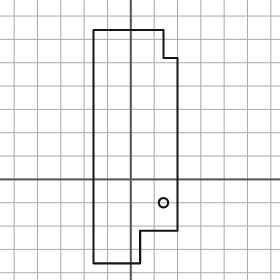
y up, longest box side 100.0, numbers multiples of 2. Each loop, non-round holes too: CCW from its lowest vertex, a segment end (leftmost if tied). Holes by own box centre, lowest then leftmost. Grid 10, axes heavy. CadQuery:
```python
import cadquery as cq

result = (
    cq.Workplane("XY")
    .moveTo(-16.0, -36.0)
    .lineTo(4.0, -36.0)
    .lineTo(4.0, -22.0)
    .lineTo(20.0, -22.0)
    .lineTo(20.0, 52.0)
    .lineTo(14.0, 52.0)
    .lineTo(14.0, 64.0)
    .lineTo(-16.0, 64.0)
    .close()
    .moveTo(14.0, -10.0)
    .circle(2.0)
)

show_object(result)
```